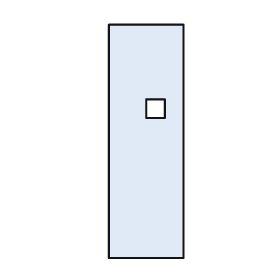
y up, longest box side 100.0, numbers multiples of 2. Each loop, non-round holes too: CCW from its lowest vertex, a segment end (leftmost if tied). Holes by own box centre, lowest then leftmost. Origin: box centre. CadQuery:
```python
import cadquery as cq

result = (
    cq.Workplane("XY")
    .moveTo(-16.0, -50.0)
    .lineTo(16.0, -50.0)
    .lineTo(16.0, 50.0)
    .lineTo(-16.0, 50.0)
    .close()
    .moveTo(0.0, 10.0)
    .lineTo(8.0, 10.0)
    .lineTo(8.0, 18.0)
    .lineTo(0.0, 18.0)
    .close()
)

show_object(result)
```